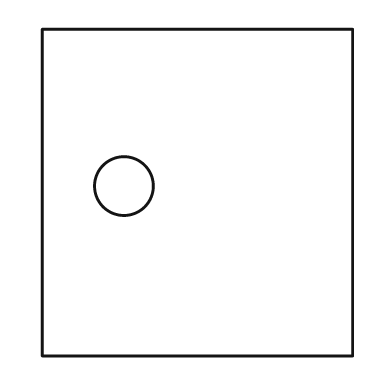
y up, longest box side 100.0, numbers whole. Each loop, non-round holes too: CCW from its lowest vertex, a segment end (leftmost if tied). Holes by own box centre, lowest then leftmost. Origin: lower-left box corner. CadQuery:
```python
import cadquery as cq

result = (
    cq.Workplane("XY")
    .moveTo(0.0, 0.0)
    .lineTo(95.0, 0.0)
    .lineTo(95.0, 100.0)
    .lineTo(0.0, 100.0)
    .close()
    .moveTo(25.0, 52.0)
    .circle(9.0)
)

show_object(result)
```